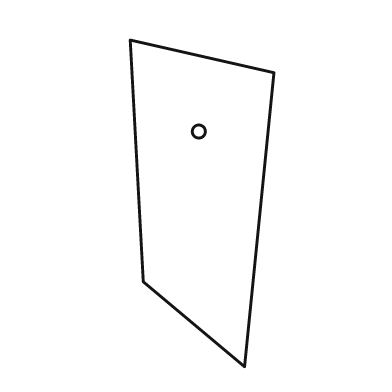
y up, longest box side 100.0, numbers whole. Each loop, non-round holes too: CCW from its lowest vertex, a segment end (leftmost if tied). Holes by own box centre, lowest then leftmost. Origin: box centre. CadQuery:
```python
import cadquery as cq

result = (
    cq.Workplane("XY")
    .moveTo(13.0, -50.0)
    .lineTo(22.0, 40.0)
    .lineTo(-22.0, 50.0)
    .lineTo(-18.0, -24.0)
    .close()
    .moveTo(-1.0, 22.0)
    .circle(2.0)
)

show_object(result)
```